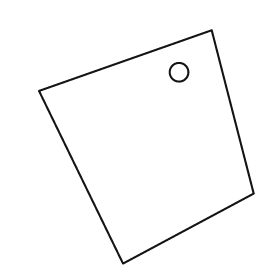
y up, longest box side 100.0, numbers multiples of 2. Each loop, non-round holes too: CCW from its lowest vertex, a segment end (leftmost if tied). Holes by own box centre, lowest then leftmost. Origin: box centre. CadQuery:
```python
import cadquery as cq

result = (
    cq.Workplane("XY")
    .moveTo(-10.0, -50.0)
    .lineTo(46.0, -20.0)
    .lineTo(28.0, 50.0)
    .lineTo(-46.0, 24.0)
    .close()
    .moveTo(14.0, 32.0)
    .circle(4.0)
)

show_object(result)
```